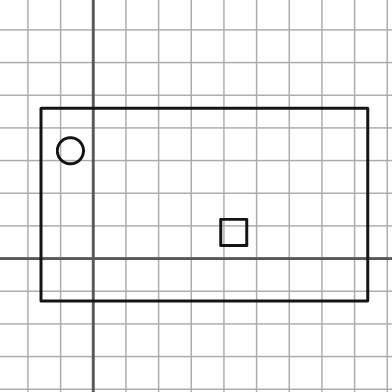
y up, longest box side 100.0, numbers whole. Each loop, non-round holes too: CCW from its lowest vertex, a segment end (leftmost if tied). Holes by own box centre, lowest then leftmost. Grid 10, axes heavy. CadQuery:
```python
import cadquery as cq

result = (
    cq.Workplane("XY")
    .moveTo(-16.0, -13.0)
    .lineTo(84.0, -13.0)
    .lineTo(84.0, 46.0)
    .lineTo(-16.0, 46.0)
    .close()
    .moveTo(39.0, 4.0)
    .lineTo(47.0, 4.0)
    .lineTo(47.0, 12.0)
    .lineTo(39.0, 12.0)
    .close()
    .moveTo(-7.0, 33.0)
    .circle(4.0)
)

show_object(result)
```